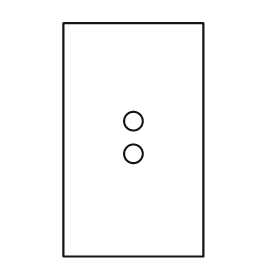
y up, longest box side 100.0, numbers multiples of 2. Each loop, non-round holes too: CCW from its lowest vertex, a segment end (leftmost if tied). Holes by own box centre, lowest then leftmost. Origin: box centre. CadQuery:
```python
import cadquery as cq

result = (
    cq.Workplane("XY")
    .moveTo(-30.0, -50.0)
    .lineTo(30.0, -50.0)
    .lineTo(30.0, 50.0)
    .lineTo(-30.0, 50.0)
    .close()
    .moveTo(0.0, -6.0)
    .circle(4.0)
    .moveTo(0.0, 8.0)
    .circle(4.0)
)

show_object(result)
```